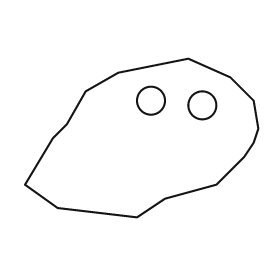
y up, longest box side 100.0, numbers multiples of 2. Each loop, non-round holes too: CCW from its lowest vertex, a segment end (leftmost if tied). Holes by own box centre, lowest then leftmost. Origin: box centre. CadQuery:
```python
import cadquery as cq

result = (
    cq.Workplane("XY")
    .moveTo(-2.0, -34.0)
    .lineTo(10.0, -26.0)
    .lineTo(32.0, -20.0)
    .lineTo(44.0, -8.0)
    .lineTo(48.0, -2.0)
    .lineTo(50.0, 4.0)
    .lineTo(48.0, 16.0)
    .lineTo(38.0, 26.0)
    .lineTo(20.0, 34.0)
    .lineTo(-10.0, 28.0)
    .lineTo(-24.0, 20.0)
    .lineTo(-32.0, 6.0)
    .lineTo(-38.0, 0.0)
    .lineTo(-50.0, -20.0)
    .lineTo(-36.0, -30.0)
    .close()
    .moveTo(26.0, 14.0)
    .circle(6.0)
    .moveTo(4.0, 16.0)
    .circle(6.0)
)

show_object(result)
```